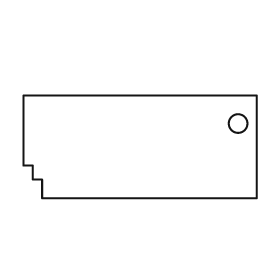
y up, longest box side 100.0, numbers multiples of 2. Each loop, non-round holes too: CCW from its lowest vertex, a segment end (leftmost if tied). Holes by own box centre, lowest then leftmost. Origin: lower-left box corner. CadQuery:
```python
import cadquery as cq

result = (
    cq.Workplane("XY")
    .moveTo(8.0, 0.0)
    .lineTo(100.0, 0.0)
    .lineTo(100.0, 44.0)
    .lineTo(0.0, 44.0)
    .lineTo(0.0, 14.0)
    .lineTo(4.0, 14.0)
    .lineTo(4.0, 8.0)
    .lineTo(8.0, 8.0)
    .close()
    .moveTo(92.0, 32.0)
    .circle(4.0)
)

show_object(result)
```